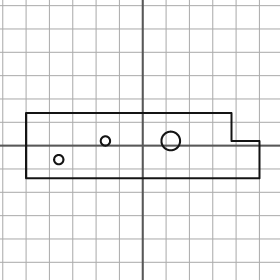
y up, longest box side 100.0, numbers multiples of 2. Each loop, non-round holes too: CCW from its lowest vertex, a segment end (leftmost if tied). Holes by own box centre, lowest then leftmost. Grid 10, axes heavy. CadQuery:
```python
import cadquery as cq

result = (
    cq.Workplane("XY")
    .moveTo(-50.0, -14.0)
    .lineTo(50.0, -14.0)
    .lineTo(50.0, 2.0)
    .lineTo(38.0, 2.0)
    .lineTo(38.0, 14.0)
    .lineTo(-50.0, 14.0)
    .close()
    .moveTo(-36.0, -6.0)
    .circle(2.0)
    .moveTo(-16.0, 2.0)
    .circle(2.0)
    .moveTo(12.0, 2.0)
    .circle(4.0)
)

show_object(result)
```